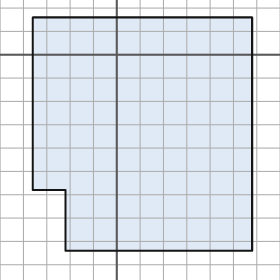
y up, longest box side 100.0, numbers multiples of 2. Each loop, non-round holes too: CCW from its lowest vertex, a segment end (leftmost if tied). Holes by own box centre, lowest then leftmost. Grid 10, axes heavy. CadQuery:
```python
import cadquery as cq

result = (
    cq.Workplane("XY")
    .moveTo(-22.0, -84.0)
    .lineTo(58.0, -84.0)
    .lineTo(58.0, 16.0)
    .lineTo(-36.0, 16.0)
    .lineTo(-36.0, -58.0)
    .lineTo(-22.0, -58.0)
    .close()
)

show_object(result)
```